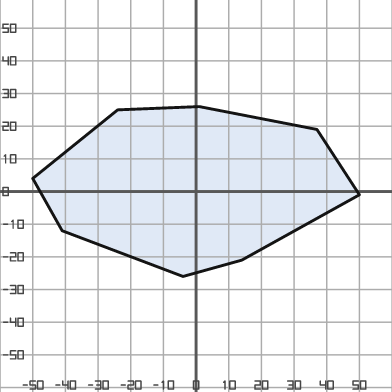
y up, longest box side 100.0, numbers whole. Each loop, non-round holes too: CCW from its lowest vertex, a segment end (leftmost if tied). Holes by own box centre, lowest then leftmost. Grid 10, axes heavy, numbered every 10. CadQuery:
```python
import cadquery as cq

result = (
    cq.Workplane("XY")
    .moveTo(-4.0, -26.0)
    .lineTo(14.0, -21.0)
    .lineTo(50.0, -1.0)
    .lineTo(37.0, 19.0)
    .lineTo(1.0, 26.0)
    .lineTo(-24.0, 25.0)
    .lineTo(-50.0, 4.0)
    .lineTo(-41.0, -12.0)
    .close()
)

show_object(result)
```